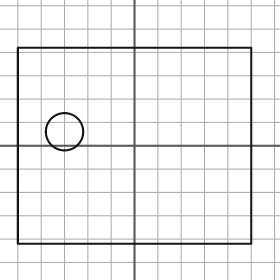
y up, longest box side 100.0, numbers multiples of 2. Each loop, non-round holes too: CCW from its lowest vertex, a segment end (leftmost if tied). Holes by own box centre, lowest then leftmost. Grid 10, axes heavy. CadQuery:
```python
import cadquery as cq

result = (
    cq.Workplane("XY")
    .moveTo(-50.0, -42.0)
    .lineTo(50.0, -42.0)
    .lineTo(50.0, 42.0)
    .lineTo(-50.0, 42.0)
    .close()
    .moveTo(-30.0, 6.0)
    .circle(8.0)
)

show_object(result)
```